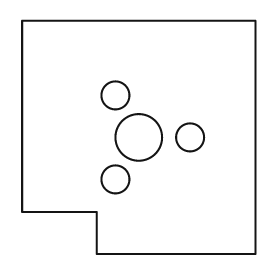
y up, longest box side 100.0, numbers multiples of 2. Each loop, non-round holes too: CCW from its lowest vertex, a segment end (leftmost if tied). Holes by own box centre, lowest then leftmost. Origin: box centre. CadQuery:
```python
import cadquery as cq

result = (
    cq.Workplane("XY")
    .moveTo(-18.0, -50.0)
    .lineTo(50.0, -50.0)
    .lineTo(50.0, 50.0)
    .lineTo(-50.0, 50.0)
    .lineTo(-50.0, -32.0)
    .lineTo(-18.0, -32.0)
    .close()
    .moveTo(-10.0, -18.0)
    .circle(6.0)
    .moveTo(0.0, 0.0)
    .circle(10.0)
    .moveTo(22.0, 0.0)
    .circle(6.0)
    .moveTo(-10.0, 18.0)
    .circle(6.0)
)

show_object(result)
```